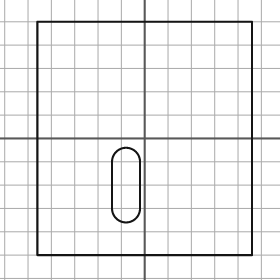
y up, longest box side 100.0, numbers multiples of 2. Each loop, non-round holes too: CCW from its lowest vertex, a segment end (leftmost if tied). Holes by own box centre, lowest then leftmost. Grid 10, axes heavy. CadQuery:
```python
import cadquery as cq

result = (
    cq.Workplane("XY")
    .moveTo(-46.0, -50.0)
    .lineTo(46.0, -50.0)
    .lineTo(46.0, 50.0)
    .lineTo(-46.0, 50.0)
    .close()
    .moveTo(-14.0, -30.0)
    .threePointArc((-8.0, -36.0), (-2.0, -30.0))
    .lineTo(-2.0, -10.0)
    .threePointArc((-8.0, -4.0), (-14.0, -10.0))
    .close()
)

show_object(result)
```